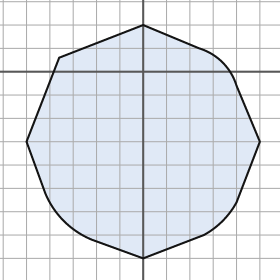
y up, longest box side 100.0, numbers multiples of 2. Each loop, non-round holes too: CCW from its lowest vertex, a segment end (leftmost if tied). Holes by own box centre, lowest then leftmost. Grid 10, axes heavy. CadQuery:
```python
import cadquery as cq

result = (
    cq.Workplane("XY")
    .moveTo(0.0, -80.0)
    .lineTo(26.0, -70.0)
    .threePointArc((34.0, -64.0), (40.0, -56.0))
    .lineTo(50.0, -30.0)
    .lineTo(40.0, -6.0)
    .threePointArc((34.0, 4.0), (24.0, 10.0))
    .lineTo(0.0, 20.0)
    .lineTo(-36.0, 6.0)
    .lineTo(-50.0, -30.0)
    .lineTo(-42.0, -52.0)
    .threePointArc((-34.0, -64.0), (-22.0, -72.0))
    .close()
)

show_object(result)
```